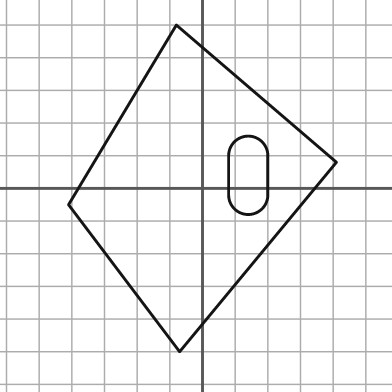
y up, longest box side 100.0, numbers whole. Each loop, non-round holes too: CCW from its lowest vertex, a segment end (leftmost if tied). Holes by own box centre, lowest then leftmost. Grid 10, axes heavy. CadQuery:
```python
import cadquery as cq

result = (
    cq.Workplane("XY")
    .moveTo(-7.0, -50.0)
    .lineTo(41.0, 8.0)
    .lineTo(-8.0, 50.0)
    .lineTo(-41.0, -5.0)
    .close()
    .moveTo(8.0, -2.0)
    .threePointArc((14.0, -8.0), (20.0, -2.0))
    .lineTo(20.0, 10.0)
    .threePointArc((14.0, 16.0), (8.0, 10.0))
    .close()
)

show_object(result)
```